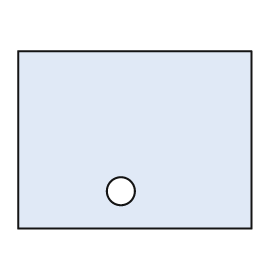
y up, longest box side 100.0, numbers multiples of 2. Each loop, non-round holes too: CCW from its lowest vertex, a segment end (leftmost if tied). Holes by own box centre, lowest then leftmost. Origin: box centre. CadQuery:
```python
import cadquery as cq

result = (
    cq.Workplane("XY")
    .moveTo(-50.0, -38.0)
    .lineTo(50.0, -38.0)
    .lineTo(50.0, 38.0)
    .lineTo(-50.0, 38.0)
    .close()
    .moveTo(-6.0, -22.0)
    .circle(6.0)
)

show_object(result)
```